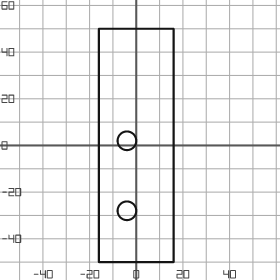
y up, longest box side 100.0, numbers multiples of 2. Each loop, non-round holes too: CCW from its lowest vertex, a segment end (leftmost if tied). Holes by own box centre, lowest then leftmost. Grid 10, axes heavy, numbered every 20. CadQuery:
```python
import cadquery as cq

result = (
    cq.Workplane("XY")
    .moveTo(-16.0, -50.0)
    .lineTo(16.0, -50.0)
    .lineTo(16.0, 50.0)
    .lineTo(-16.0, 50.0)
    .close()
    .moveTo(-4.0, -28.0)
    .circle(4.0)
    .moveTo(-4.0, 2.0)
    .circle(4.0)
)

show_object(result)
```